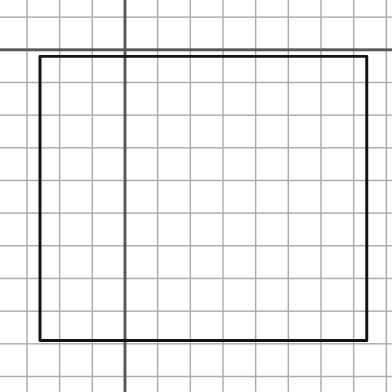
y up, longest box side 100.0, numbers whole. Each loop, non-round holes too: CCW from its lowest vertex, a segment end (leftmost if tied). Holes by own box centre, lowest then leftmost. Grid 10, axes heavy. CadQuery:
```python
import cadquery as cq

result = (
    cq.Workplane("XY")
    .moveTo(-26.0, -89.0)
    .lineTo(74.0, -89.0)
    .lineTo(74.0, -2.0)
    .lineTo(-26.0, -2.0)
    .close()
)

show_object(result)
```